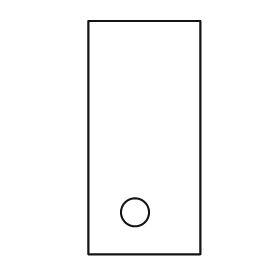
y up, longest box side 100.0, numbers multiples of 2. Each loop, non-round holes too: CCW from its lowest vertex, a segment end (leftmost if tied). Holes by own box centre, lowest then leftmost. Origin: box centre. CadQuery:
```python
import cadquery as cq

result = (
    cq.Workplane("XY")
    .moveTo(-24.0, -50.0)
    .lineTo(24.0, -50.0)
    .lineTo(24.0, 50.0)
    .lineTo(-24.0, 50.0)
    .close()
    .moveTo(-4.0, -32.0)
    .circle(6.0)
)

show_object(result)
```